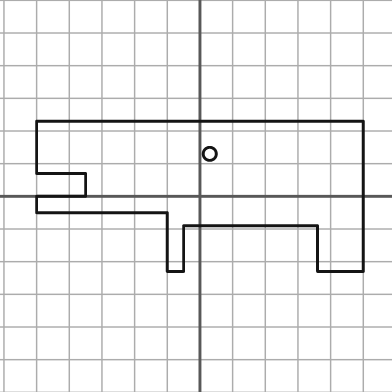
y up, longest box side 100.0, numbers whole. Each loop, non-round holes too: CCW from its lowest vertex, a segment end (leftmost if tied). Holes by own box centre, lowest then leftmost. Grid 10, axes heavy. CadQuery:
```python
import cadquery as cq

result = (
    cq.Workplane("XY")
    .moveTo(-10.0, -23.0)
    .lineTo(-5.0, -23.0)
    .lineTo(-5.0, -9.0)
    .lineTo(36.0, -9.0)
    .lineTo(36.0, -23.0)
    .lineTo(50.0, -23.0)
    .lineTo(50.0, 23.0)
    .lineTo(-50.0, 23.0)
    .lineTo(-50.0, 7.0)
    .lineTo(-35.0, 7.0)
    .lineTo(-35.0, 0.0)
    .lineTo(-50.0, 0.0)
    .lineTo(-50.0, -5.0)
    .lineTo(-10.0, -5.0)
    .close()
    .moveTo(3.0, 13.0)
    .circle(2.0)
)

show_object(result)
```